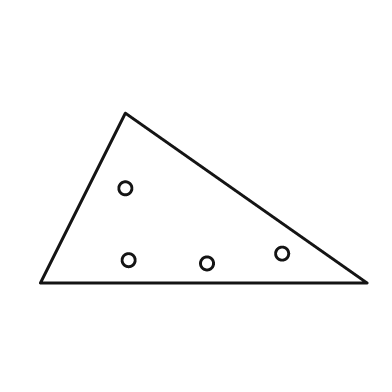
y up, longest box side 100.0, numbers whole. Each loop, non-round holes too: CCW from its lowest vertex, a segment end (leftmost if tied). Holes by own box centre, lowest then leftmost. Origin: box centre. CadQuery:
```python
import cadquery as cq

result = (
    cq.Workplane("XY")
    .moveTo(-50.0, -26.0)
    .lineTo(50.0, -26.0)
    .lineTo(-24.0, 26.0)
    .close()
    .moveTo(1.0, -20.0)
    .circle(2.0)
    .moveTo(-23.0, -19.0)
    .circle(2.0)
    .moveTo(24.0, -17.0)
    .circle(2.0)
    .moveTo(-24.0, 3.0)
    .circle(2.0)
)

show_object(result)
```